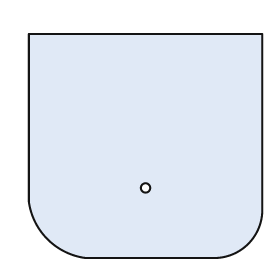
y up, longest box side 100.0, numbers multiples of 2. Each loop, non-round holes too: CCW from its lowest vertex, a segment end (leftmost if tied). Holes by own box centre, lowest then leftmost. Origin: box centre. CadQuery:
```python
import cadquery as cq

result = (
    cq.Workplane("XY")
    .moveTo(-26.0, -48.0)
    .lineTo(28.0, -48.0)
    .threePointArc((44.0, -42.0), (50.0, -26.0))
    .lineTo(50.0, 48.0)
    .lineTo(-50.0, 48.0)
    .lineTo(-50.0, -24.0)
    .threePointArc((-42.0, -40.0), (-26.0, -48.0))
    .close()
    .moveTo(0.0, -18.0)
    .circle(2.0)
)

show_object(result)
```